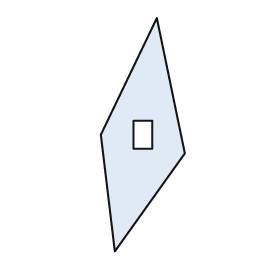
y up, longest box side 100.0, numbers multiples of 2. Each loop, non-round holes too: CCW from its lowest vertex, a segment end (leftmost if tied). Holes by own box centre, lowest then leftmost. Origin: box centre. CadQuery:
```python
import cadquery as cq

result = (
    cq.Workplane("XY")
    .moveTo(-12.0, -50.0)
    .lineTo(18.0, -8.0)
    .lineTo(6.0, 50.0)
    .lineTo(-18.0, 0.0)
    .close()
    .moveTo(-4.0, -6.0)
    .lineTo(4.0, -6.0)
    .lineTo(4.0, 6.0)
    .lineTo(-4.0, 6.0)
    .close()
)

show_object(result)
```